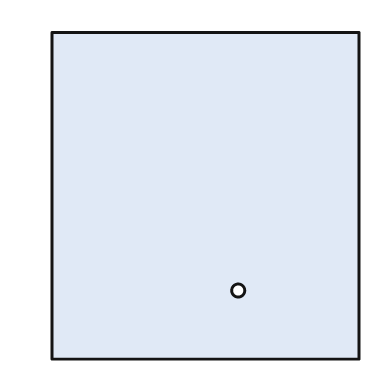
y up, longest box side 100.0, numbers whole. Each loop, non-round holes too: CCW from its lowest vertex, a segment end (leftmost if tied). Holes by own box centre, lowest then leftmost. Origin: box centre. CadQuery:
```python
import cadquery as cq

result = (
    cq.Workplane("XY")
    .moveTo(-47.0, -50.0)
    .lineTo(47.0, -50.0)
    .lineTo(47.0, 50.0)
    .lineTo(-47.0, 50.0)
    .close()
    .moveTo(10.0, -29.0)
    .circle(2.0)
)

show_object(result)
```